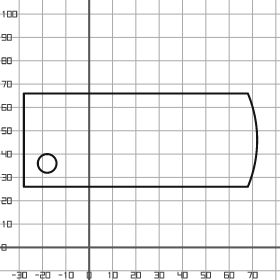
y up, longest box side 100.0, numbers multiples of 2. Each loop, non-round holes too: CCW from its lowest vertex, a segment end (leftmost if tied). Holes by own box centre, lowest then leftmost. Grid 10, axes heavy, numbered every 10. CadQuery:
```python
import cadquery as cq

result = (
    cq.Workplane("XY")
    .moveTo(-28.0, 26.0)
    .lineTo(68.0, 26.0)
    .threePointArc((72.0, 46.0), (68.0, 66.0))
    .lineTo(-28.0, 66.0)
    .close()
    .moveTo(-18.0, 36.0)
    .circle(4.0)
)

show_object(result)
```